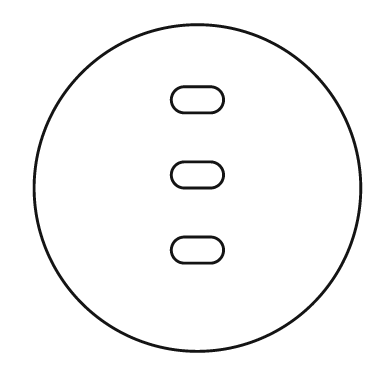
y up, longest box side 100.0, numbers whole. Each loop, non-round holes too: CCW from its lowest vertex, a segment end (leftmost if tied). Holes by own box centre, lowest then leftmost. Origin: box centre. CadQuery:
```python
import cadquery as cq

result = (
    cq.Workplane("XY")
    .moveTo(0.0, 0.0)
    .circle(50.0)
    .moveTo(-4.0, -23.0)
    .lineTo(4.0, -23.0)
    .threePointArc((8.0, -19.0), (4.0, -15.0))
    .lineTo(-4.0, -15.0)
    .threePointArc((-8.0, -19.0), (-4.0, -23.0))
    .close()
    .moveTo(-4.0, 0.0)
    .lineTo(4.0, 0.0)
    .threePointArc((8.0, 4.0), (4.0, 8.0))
    .lineTo(-4.0, 8.0)
    .threePointArc((-8.0, 4.0), (-4.0, 0.0))
    .close()
    .moveTo(-4.0, 23.0)
    .lineTo(4.0, 23.0)
    .threePointArc((8.0, 27.0), (4.0, 31.0))
    .lineTo(-4.0, 31.0)
    .threePointArc((-8.0, 27.0), (-4.0, 23.0))
    .close()
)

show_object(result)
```